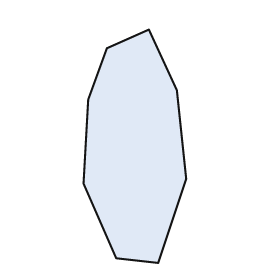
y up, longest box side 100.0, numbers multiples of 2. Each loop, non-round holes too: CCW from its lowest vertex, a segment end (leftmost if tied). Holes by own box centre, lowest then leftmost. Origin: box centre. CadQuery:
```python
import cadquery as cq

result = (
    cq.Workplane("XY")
    .moveTo(10.0, -50.0)
    .lineTo(22.0, -14.0)
    .lineTo(18.0, 24.0)
    .lineTo(6.0, 50.0)
    .lineTo(-12.0, 42.0)
    .lineTo(-20.0, 20.0)
    .lineTo(-22.0, -16.0)
    .lineTo(-8.0, -48.0)
    .close()
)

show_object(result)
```